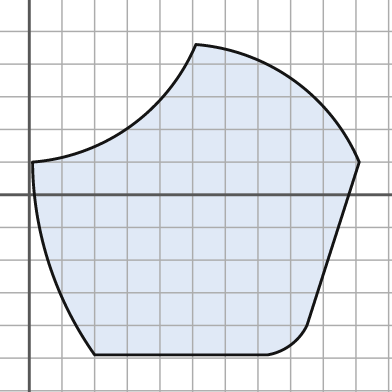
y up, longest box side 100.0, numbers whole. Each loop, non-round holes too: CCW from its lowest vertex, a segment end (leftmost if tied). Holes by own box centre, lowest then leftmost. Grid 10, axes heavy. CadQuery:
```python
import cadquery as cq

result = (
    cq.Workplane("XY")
    .moveTo(20.0, -49.0)
    .lineTo(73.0, -49.0)
    .threePointArc((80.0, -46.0), (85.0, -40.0))
    .lineTo(101.0, 10.0)
    .threePointArc((81.0, 35.0), (51.0, 46.0))
    .threePointArc((31.0, 21.0), (1.0, 10.0))
    .threePointArc((6.0, -21.0), (20.0, -49.0))
    .close()
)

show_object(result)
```